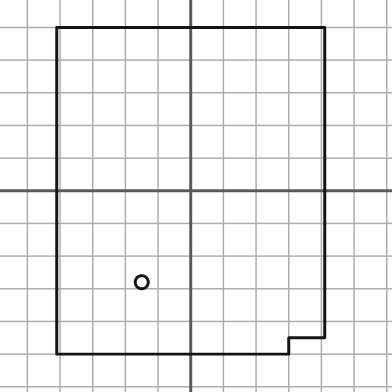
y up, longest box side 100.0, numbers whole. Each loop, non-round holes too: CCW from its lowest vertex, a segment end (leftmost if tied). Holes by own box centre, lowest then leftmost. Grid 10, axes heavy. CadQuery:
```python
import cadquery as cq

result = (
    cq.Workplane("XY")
    .moveTo(-41.0, -50.0)
    .lineTo(30.0, -50.0)
    .lineTo(30.0, -45.0)
    .lineTo(41.0, -45.0)
    .lineTo(41.0, 50.0)
    .lineTo(-41.0, 50.0)
    .close()
    .moveTo(-15.0, -28.0)
    .circle(2.0)
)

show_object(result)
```